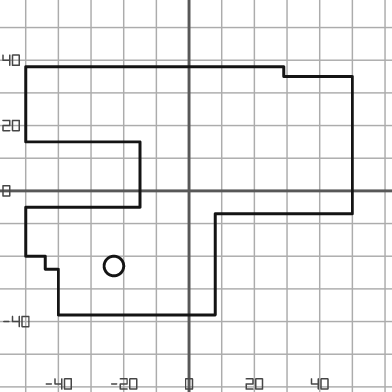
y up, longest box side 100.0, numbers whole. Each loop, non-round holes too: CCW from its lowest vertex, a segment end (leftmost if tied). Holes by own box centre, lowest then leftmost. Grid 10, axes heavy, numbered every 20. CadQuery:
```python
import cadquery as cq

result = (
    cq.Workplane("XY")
    .moveTo(-40.0, -38.0)
    .lineTo(8.0, -38.0)
    .lineTo(8.0, -7.0)
    .lineTo(50.0, -7.0)
    .lineTo(50.0, 35.0)
    .lineTo(29.0, 35.0)
    .lineTo(29.0, 38.0)
    .lineTo(-50.0, 38.0)
    .lineTo(-50.0, 15.0)
    .lineTo(-15.0, 15.0)
    .lineTo(-15.0, -5.0)
    .lineTo(-50.0, -5.0)
    .lineTo(-50.0, -20.0)
    .lineTo(-44.0, -20.0)
    .lineTo(-44.0, -24.0)
    .lineTo(-40.0, -24.0)
    .close()
    .moveTo(-23.0, -23.0)
    .circle(3.0)
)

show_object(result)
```